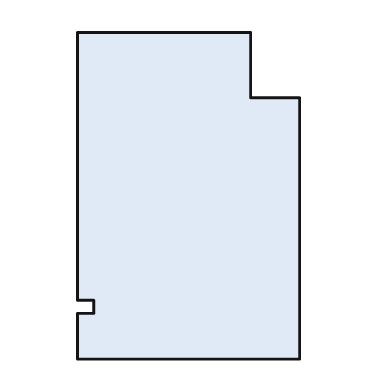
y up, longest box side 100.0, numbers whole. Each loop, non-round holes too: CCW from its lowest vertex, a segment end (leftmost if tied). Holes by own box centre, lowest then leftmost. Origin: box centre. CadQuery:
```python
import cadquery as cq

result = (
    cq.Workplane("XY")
    .moveTo(-34.0, -50.0)
    .lineTo(34.0, -50.0)
    .lineTo(34.0, 30.0)
    .lineTo(19.0, 30.0)
    .lineTo(19.0, 50.0)
    .lineTo(-34.0, 50.0)
    .lineTo(-34.0, -32.0)
    .lineTo(-29.0, -32.0)
    .lineTo(-29.0, -36.0)
    .lineTo(-34.0, -36.0)
    .close()
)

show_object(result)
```